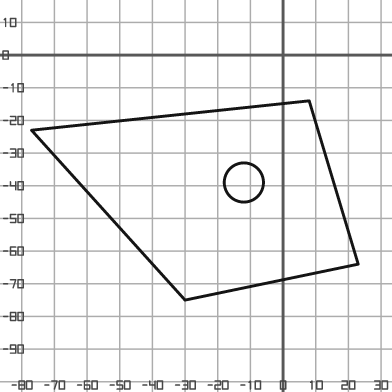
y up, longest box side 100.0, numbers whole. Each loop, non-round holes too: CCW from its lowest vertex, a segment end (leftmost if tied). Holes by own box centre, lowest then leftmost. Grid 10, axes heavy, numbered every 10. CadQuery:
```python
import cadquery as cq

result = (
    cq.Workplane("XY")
    .moveTo(-30.0, -75.0)
    .lineTo(23.0, -64.0)
    .lineTo(8.0, -14.0)
    .lineTo(-77.0, -23.0)
    .close()
    .moveTo(-12.0, -39.0)
    .circle(6.0)
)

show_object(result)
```